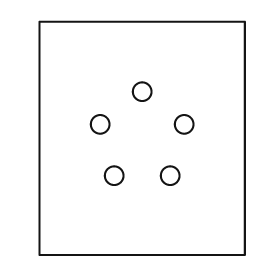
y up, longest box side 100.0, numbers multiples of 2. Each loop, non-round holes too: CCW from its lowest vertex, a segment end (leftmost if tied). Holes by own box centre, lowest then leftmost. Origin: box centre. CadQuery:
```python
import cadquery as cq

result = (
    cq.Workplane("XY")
    .moveTo(-44.0, -50.0)
    .lineTo(44.0, -50.0)
    .lineTo(44.0, 50.0)
    .lineTo(-44.0, 50.0)
    .close()
    .moveTo(-12.0, -16.0)
    .circle(4.0)
    .moveTo(12.0, -16.0)
    .circle(4.0)
    .moveTo(-18.0, 6.0)
    .circle(4.0)
    .moveTo(18.0, 6.0)
    .circle(4.0)
    .moveTo(0.0, 20.0)
    .circle(4.0)
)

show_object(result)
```